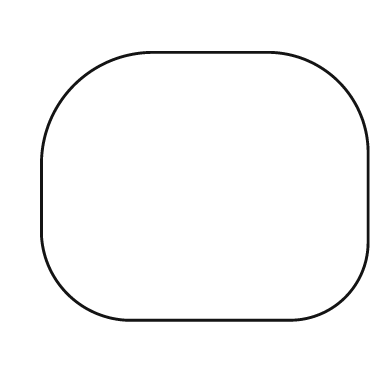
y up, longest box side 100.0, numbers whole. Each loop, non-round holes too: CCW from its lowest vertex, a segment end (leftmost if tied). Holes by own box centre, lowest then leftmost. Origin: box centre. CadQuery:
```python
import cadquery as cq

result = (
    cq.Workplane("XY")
    .moveTo(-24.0, -41.0)
    .lineTo(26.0, -41.0)
    .threePointArc((43.0, -34.0), (50.0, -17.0))
    .lineTo(50.0, 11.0)
    .threePointArc((41.0, 32.0), (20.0, 41.0))
    .lineTo(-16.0, 41.0)
    .threePointArc((-40.0, 31.0), (-50.0, 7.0))
    .lineTo(-50.0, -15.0)
    .threePointArc((-42.0, -33.0), (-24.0, -41.0))
    .close()
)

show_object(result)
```